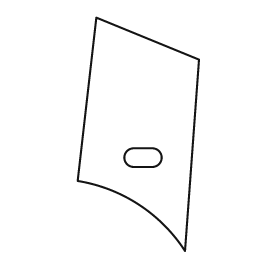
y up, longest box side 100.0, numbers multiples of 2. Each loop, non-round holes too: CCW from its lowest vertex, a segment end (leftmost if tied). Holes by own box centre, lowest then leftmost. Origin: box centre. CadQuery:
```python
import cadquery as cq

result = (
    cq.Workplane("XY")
    .moveTo(20.0, -50.0)
    .lineTo(26.0, 32.0)
    .lineTo(-18.0, 50.0)
    .lineTo(-26.0, -20.0)
    .threePointArc((0.0, -30.0), (20.0, -50.0))
    .close()
    .moveTo(-2.0, -14.0)
    .lineTo(6.0, -14.0)
    .threePointArc((10.0, -10.0), (6.0, -6.0))
    .lineTo(-2.0, -6.0)
    .threePointArc((-6.0, -10.0), (-2.0, -14.0))
    .close()
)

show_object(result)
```